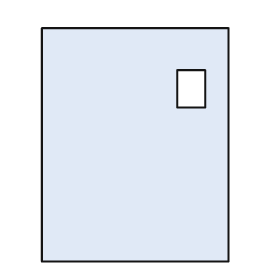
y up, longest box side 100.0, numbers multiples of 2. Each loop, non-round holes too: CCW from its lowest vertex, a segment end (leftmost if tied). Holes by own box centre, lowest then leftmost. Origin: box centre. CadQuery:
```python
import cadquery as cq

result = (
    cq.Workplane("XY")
    .moveTo(-40.0, -50.0)
    .lineTo(40.0, -50.0)
    .lineTo(40.0, 50.0)
    .lineTo(-40.0, 50.0)
    .close()
    .moveTo(18.0, 16.0)
    .lineTo(30.0, 16.0)
    .lineTo(30.0, 32.0)
    .lineTo(18.0, 32.0)
    .close()
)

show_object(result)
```